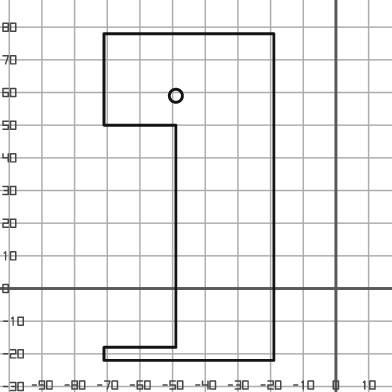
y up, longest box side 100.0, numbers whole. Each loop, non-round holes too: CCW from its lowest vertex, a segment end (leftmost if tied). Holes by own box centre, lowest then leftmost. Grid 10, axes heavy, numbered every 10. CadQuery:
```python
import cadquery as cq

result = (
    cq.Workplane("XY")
    .moveTo(-71.0, -22.0)
    .lineTo(-19.0, -22.0)
    .lineTo(-19.0, 78.0)
    .lineTo(-71.0, 78.0)
    .lineTo(-71.0, 50.0)
    .lineTo(-49.0, 50.0)
    .lineTo(-49.0, -18.0)
    .lineTo(-71.0, -18.0)
    .close()
    .moveTo(-49.0, 59.0)
    .circle(2.0)
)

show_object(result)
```